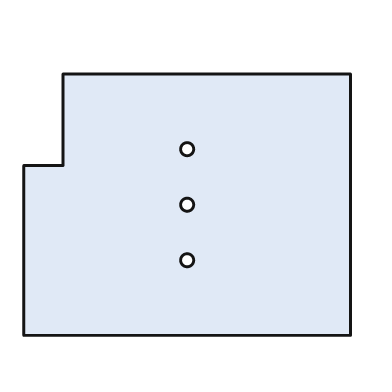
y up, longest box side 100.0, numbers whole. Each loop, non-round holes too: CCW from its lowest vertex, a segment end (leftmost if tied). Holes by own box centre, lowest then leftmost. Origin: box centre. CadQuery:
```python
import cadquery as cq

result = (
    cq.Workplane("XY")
    .moveTo(-50.0, -40.0)
    .lineTo(50.0, -40.0)
    .lineTo(50.0, 40.0)
    .lineTo(-38.0, 40.0)
    .lineTo(-38.0, 12.0)
    .lineTo(-50.0, 12.0)
    .close()
    .moveTo(0.0, -17.0)
    .circle(2.0)
    .moveTo(0.0, 0.0)
    .circle(2.0)
    .moveTo(0.0, 17.0)
    .circle(2.0)
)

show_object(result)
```